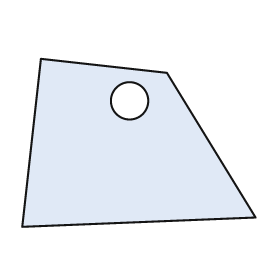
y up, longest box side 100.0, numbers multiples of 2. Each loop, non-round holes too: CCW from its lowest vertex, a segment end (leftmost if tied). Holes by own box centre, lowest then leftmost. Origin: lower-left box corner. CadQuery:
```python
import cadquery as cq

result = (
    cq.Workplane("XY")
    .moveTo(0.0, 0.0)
    .lineTo(100.0, 4.0)
    .lineTo(62.0, 66.0)
    .lineTo(8.0, 72.0)
    .close()
    .moveTo(46.0, 54.0)
    .circle(8.0)
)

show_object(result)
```